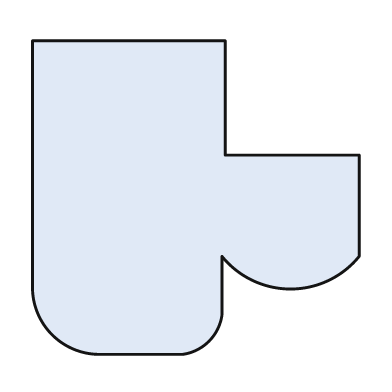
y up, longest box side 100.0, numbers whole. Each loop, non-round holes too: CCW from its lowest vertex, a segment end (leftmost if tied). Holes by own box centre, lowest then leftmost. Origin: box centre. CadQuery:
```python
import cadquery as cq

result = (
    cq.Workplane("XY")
    .moveTo(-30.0, -48.0)
    .lineTo(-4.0, -48.0)
    .threePointArc((4.0, -44.0), (8.0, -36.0))
    .lineTo(8.0, -18.0)
    .threePointArc((29.0, -28.0), (50.0, -18.0))
    .lineTo(50.0, 13.0)
    .lineTo(9.0, 13.0)
    .lineTo(9.0, 48.0)
    .lineTo(-50.0, 48.0)
    .lineTo(-50.0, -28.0)
    .threePointArc((-44.0, -42.0), (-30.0, -48.0))
    .close()
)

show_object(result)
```